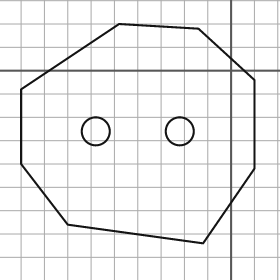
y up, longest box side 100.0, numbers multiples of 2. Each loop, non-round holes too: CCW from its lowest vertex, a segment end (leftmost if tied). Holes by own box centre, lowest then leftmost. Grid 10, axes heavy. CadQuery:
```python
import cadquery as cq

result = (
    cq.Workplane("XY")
    .moveTo(-12.0, -74.0)
    .lineTo(10.0, -42.0)
    .lineTo(10.0, -4.0)
    .lineTo(-14.0, 18.0)
    .lineTo(-48.0, 20.0)
    .lineTo(-90.0, -8.0)
    .lineTo(-90.0, -40.0)
    .lineTo(-70.0, -66.0)
    .close()
    .moveTo(-58.0, -26.0)
    .circle(6.0)
    .moveTo(-22.0, -26.0)
    .circle(6.0)
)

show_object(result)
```